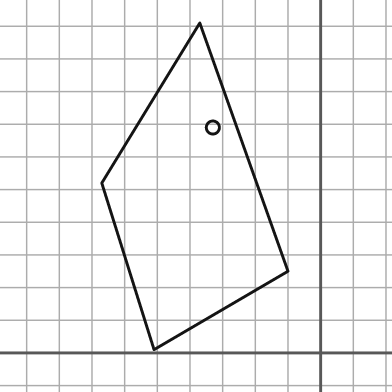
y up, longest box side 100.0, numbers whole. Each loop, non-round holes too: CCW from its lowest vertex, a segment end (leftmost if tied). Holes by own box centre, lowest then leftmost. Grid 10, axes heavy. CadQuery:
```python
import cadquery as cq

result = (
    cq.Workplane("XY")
    .moveTo(-51.0, 1.0)
    .lineTo(-10.0, 25.0)
    .lineTo(-37.0, 101.0)
    .lineTo(-67.0, 52.0)
    .close()
    .moveTo(-33.0, 69.0)
    .circle(2.0)
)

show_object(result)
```